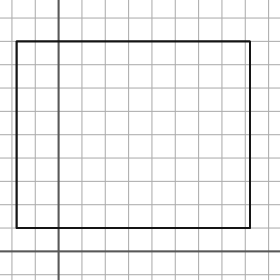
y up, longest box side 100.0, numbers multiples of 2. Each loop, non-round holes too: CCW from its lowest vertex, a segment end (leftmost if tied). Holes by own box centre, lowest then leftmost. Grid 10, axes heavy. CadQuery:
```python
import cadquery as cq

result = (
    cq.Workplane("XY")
    .moveTo(-18.0, 10.0)
    .lineTo(82.0, 10.0)
    .lineTo(82.0, 90.0)
    .lineTo(-18.0, 90.0)
    .close()
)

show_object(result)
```